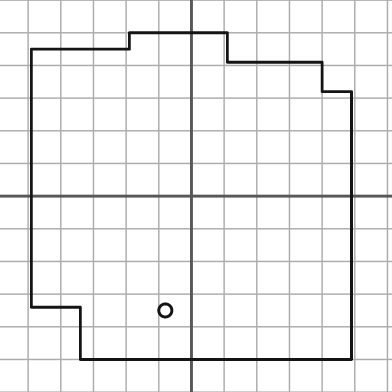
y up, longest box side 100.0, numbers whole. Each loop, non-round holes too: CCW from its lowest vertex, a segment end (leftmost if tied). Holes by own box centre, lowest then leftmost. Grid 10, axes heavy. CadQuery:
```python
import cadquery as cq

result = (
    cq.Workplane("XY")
    .moveTo(-34.0, -50.0)
    .lineTo(49.0, -50.0)
    .lineTo(49.0, 32.0)
    .lineTo(40.0, 32.0)
    .lineTo(40.0, 41.0)
    .lineTo(11.0, 41.0)
    .lineTo(11.0, 50.0)
    .lineTo(-19.0, 50.0)
    .lineTo(-19.0, 45.0)
    .lineTo(-49.0, 45.0)
    .lineTo(-49.0, -34.0)
    .lineTo(-34.0, -34.0)
    .close()
    .moveTo(-8.0, -35.0)
    .circle(2.0)
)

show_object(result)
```